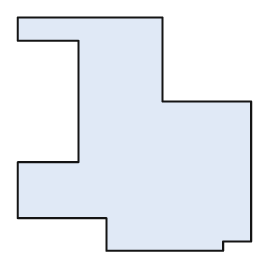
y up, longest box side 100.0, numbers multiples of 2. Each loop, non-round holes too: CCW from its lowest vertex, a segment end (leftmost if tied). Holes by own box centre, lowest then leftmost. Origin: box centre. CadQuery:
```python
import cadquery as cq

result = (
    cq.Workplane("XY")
    .moveTo(-12.0, -50.0)
    .lineTo(38.0, -50.0)
    .lineTo(38.0, -46.0)
    .lineTo(50.0, -46.0)
    .lineTo(50.0, 14.0)
    .lineTo(12.0, 14.0)
    .lineTo(12.0, 50.0)
    .lineTo(-50.0, 50.0)
    .lineTo(-50.0, 40.0)
    .lineTo(-24.0, 40.0)
    .lineTo(-24.0, -12.0)
    .lineTo(-50.0, -12.0)
    .lineTo(-50.0, -36.0)
    .lineTo(-12.0, -36.0)
    .close()
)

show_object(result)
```